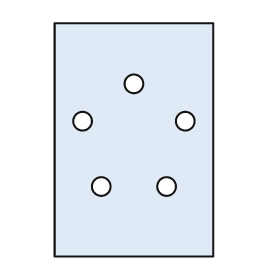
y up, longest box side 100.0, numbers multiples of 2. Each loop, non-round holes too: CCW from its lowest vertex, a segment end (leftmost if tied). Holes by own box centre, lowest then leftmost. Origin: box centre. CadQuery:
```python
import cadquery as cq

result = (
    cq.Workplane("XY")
    .moveTo(-34.0, -50.0)
    .lineTo(34.0, -50.0)
    .lineTo(34.0, 50.0)
    .lineTo(-34.0, 50.0)
    .close()
    .moveTo(-14.0, -20.0)
    .circle(4.0)
    .moveTo(14.0, -20.0)
    .circle(4.0)
    .moveTo(-22.0, 8.0)
    .circle(4.0)
    .moveTo(22.0, 8.0)
    .circle(4.0)
    .moveTo(0.0, 24.0)
    .circle(4.0)
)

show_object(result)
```